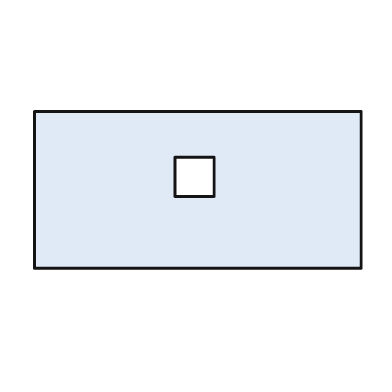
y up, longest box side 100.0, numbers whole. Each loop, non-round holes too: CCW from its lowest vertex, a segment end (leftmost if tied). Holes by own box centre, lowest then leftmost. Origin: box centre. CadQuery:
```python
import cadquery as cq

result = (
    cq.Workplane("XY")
    .moveTo(-50.0, -24.0)
    .lineTo(50.0, -24.0)
    .lineTo(50.0, 24.0)
    .lineTo(-50.0, 24.0)
    .close()
    .moveTo(-7.0, -2.0)
    .lineTo(5.0, -2.0)
    .lineTo(5.0, 10.0)
    .lineTo(-7.0, 10.0)
    .close()
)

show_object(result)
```